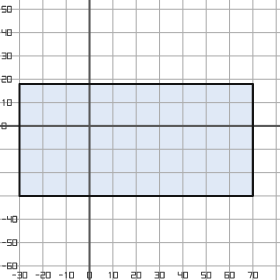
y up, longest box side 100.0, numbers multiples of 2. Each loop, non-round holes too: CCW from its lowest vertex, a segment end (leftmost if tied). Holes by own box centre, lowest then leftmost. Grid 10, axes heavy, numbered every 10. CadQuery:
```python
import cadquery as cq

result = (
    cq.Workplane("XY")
    .moveTo(-30.0, -30.0)
    .lineTo(70.0, -30.0)
    .lineTo(70.0, 18.0)
    .lineTo(-30.0, 18.0)
    .close()
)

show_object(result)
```